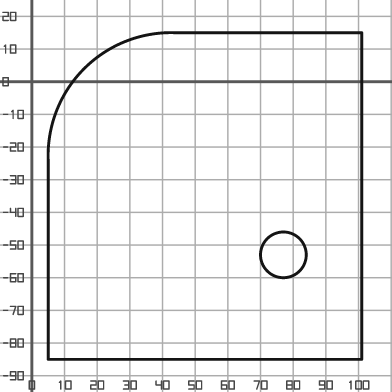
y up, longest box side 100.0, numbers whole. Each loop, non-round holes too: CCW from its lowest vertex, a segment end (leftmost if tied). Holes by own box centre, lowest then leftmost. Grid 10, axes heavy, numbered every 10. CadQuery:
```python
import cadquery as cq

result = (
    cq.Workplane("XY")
    .moveTo(5.0, -85.0)
    .lineTo(101.0, -85.0)
    .lineTo(101.0, 15.0)
    .lineTo(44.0, 15.0)
    .threePointArc((16.0, 4.0), (5.0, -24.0))
    .close()
    .moveTo(77.0, -53.0)
    .circle(7.0)
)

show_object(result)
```